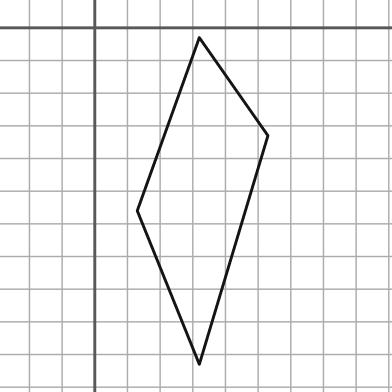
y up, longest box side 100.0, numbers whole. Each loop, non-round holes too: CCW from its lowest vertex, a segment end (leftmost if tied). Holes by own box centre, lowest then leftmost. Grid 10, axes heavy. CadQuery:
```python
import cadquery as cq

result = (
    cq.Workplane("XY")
    .moveTo(32.0, -103.0)
    .lineTo(53.0, -33.0)
    .lineTo(32.0, -3.0)
    .lineTo(13.0, -56.0)
    .close()
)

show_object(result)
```